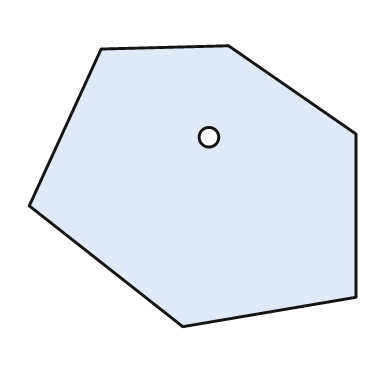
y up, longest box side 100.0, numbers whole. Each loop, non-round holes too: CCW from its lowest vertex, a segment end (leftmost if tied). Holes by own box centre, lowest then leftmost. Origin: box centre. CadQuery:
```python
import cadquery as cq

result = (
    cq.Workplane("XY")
    .moveTo(-3.0, -43.0)
    .lineTo(50.0, -34.0)
    .lineTo(50.0, 16.0)
    .lineTo(11.0, 43.0)
    .lineTo(-28.0, 42.0)
    .lineTo(-50.0, -6.0)
    .close()
    .moveTo(5.0, 15.0)
    .circle(3.0)
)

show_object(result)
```